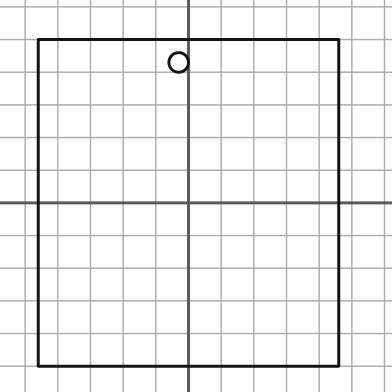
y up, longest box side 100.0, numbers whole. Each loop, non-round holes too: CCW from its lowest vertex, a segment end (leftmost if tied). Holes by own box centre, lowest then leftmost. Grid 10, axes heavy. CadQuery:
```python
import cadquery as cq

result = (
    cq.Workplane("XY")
    .moveTo(-46.0, -50.0)
    .lineTo(46.0, -50.0)
    .lineTo(46.0, 50.0)
    .lineTo(-46.0, 50.0)
    .close()
    .moveTo(-3.0, 43.0)
    .circle(3.0)
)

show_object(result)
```